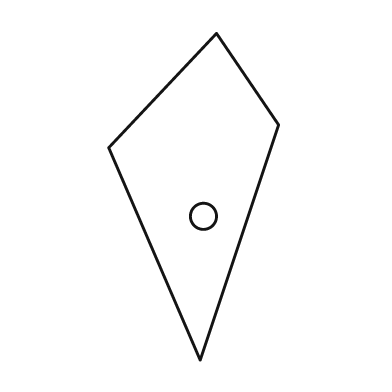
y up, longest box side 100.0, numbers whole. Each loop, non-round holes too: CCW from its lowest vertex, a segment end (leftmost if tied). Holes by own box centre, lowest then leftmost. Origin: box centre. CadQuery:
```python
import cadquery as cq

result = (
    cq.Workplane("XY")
    .moveTo(2.0, -50.0)
    .lineTo(26.0, 22.0)
    .lineTo(7.0, 50.0)
    .lineTo(-26.0, 15.0)
    .close()
    .moveTo(3.0, -6.0)
    .circle(4.0)
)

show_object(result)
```